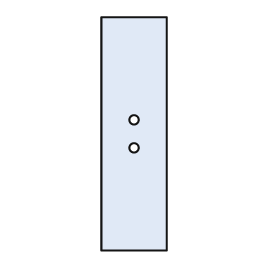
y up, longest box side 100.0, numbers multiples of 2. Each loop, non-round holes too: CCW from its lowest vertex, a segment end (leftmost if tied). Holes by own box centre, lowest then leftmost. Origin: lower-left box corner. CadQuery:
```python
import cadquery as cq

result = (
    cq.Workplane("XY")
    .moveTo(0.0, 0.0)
    .lineTo(28.0, 0.0)
    .lineTo(28.0, 100.0)
    .lineTo(0.0, 100.0)
    .close()
    .moveTo(14.0, 44.0)
    .circle(2.0)
    .moveTo(14.0, 56.0)
    .circle(2.0)
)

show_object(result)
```